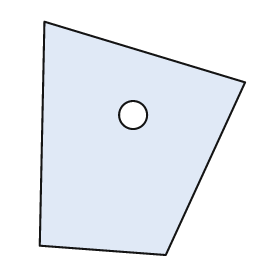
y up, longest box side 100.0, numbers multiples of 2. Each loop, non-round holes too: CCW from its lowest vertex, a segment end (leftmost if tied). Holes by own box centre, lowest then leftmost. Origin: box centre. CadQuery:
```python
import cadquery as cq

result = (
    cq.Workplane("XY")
    .moveTo(10.0, -50.0)
    .lineTo(44.0, 24.0)
    .lineTo(-42.0, 50.0)
    .lineTo(-44.0, -46.0)
    .close()
    .moveTo(-4.0, 10.0)
    .circle(6.0)
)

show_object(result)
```